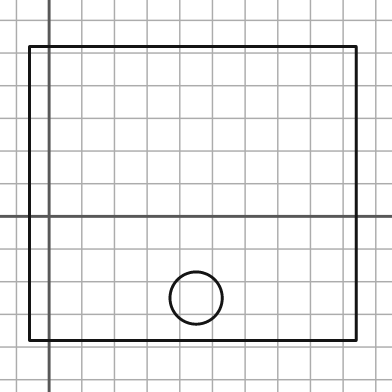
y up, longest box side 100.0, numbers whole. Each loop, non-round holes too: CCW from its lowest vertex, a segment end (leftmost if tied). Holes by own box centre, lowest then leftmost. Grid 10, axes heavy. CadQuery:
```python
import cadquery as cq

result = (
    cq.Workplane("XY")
    .moveTo(-6.0, -38.0)
    .lineTo(94.0, -38.0)
    .lineTo(94.0, 52.0)
    .lineTo(-6.0, 52.0)
    .close()
    .moveTo(45.0, -25.0)
    .circle(8.0)
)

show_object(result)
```